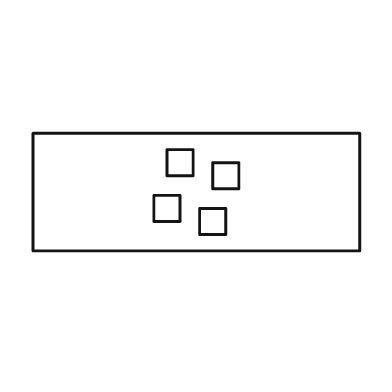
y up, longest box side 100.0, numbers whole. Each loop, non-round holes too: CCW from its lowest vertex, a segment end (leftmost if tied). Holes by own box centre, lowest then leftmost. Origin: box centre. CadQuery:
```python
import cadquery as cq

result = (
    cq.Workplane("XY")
    .moveTo(-50.0, -18.0)
    .lineTo(50.0, -18.0)
    .lineTo(50.0, 18.0)
    .lineTo(-50.0, 18.0)
    .close()
    .moveTo(1.0, -13.0)
    .lineTo(9.0, -13.0)
    .lineTo(9.0, -5.0)
    .lineTo(1.0, -5.0)
    .close()
    .moveTo(-13.0, -9.0)
    .lineTo(-5.0, -9.0)
    .lineTo(-5.0, -1.0)
    .lineTo(-13.0, -1.0)
    .close()
    .moveTo(5.0, 1.0)
    .lineTo(13.0, 1.0)
    .lineTo(13.0, 9.0)
    .lineTo(5.0, 9.0)
    .close()
    .moveTo(-9.0, 5.0)
    .lineTo(-1.0, 5.0)
    .lineTo(-1.0, 13.0)
    .lineTo(-9.0, 13.0)
    .close()
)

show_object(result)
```